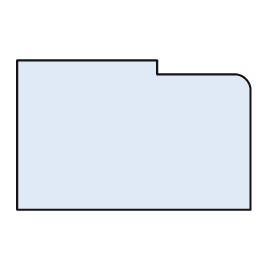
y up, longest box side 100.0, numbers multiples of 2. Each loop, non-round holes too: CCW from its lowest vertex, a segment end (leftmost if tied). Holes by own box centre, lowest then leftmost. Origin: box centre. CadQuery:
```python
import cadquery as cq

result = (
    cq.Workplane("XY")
    .moveTo(-50.0, -32.0)
    .lineTo(50.0, -32.0)
    .lineTo(50.0, 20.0)
    .threePointArc((48.0, 24.0), (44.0, 26.0))
    .lineTo(10.0, 26.0)
    .lineTo(10.0, 32.0)
    .lineTo(-50.0, 32.0)
    .close()
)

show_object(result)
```